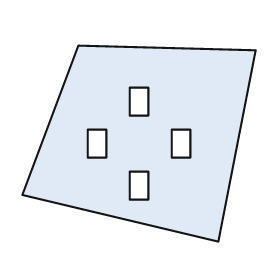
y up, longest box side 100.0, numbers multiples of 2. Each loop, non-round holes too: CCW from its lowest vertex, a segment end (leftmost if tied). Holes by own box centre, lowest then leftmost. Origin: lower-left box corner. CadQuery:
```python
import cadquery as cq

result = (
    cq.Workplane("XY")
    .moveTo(84.0, 0.0)
    .lineTo(100.0, 82.0)
    .lineTo(24.0, 84.0)
    .lineTo(0.0, 20.0)
    .close()
    .moveTo(46.0, 18.0)
    .lineTo(54.0, 18.0)
    .lineTo(54.0, 30.0)
    .lineTo(46.0, 30.0)
    .close()
    .moveTo(28.0, 36.0)
    .lineTo(36.0, 36.0)
    .lineTo(36.0, 48.0)
    .lineTo(28.0, 48.0)
    .close()
    .moveTo(64.0, 36.0)
    .lineTo(72.0, 36.0)
    .lineTo(72.0, 48.0)
    .lineTo(64.0, 48.0)
    .close()
    .moveTo(46.0, 54.0)
    .lineTo(54.0, 54.0)
    .lineTo(54.0, 66.0)
    .lineTo(46.0, 66.0)
    .close()
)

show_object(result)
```